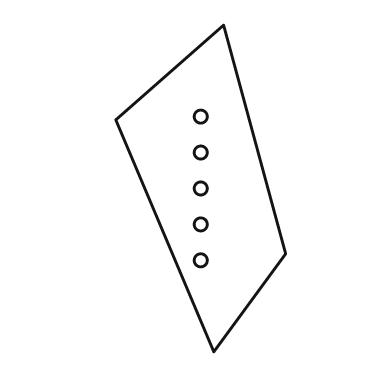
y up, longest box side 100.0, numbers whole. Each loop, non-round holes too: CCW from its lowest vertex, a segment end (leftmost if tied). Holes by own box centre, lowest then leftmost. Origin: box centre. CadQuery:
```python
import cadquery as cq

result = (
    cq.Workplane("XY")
    .moveTo(4.0, -50.0)
    .lineTo(26.0, -20.0)
    .lineTo(7.0, 50.0)
    .lineTo(-26.0, 21.0)
    .close()
    .moveTo(0.0, -22.0)
    .circle(2.0)
    .moveTo(0.0, -11.0)
    .circle(2.0)
    .moveTo(0.0, 0.0)
    .circle(2.0)
    .moveTo(0.0, 11.0)
    .circle(2.0)
    .moveTo(0.0, 22.0)
    .circle(2.0)
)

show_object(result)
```